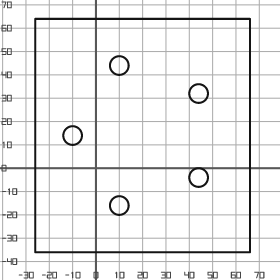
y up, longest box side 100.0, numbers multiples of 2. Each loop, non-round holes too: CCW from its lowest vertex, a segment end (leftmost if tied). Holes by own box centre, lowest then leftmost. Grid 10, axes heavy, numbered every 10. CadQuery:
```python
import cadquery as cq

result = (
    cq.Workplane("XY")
    .moveTo(-26.0, -36.0)
    .lineTo(66.0, -36.0)
    .lineTo(66.0, 64.0)
    .lineTo(-26.0, 64.0)
    .close()
    .moveTo(10.0, -16.0)
    .circle(4.0)
    .moveTo(44.0, -4.0)
    .circle(4.0)
    .moveTo(-10.0, 14.0)
    .circle(4.0)
    .moveTo(44.0, 32.0)
    .circle(4.0)
    .moveTo(10.0, 44.0)
    .circle(4.0)
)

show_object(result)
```